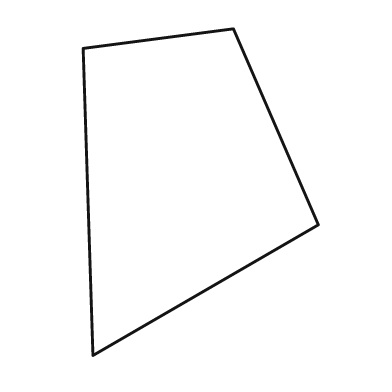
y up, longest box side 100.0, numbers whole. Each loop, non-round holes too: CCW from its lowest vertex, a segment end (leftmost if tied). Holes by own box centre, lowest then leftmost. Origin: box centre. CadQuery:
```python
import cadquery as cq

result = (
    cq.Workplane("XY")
    .moveTo(-33.0, -50.0)
    .lineTo(36.0, -10.0)
    .lineTo(10.0, 50.0)
    .lineTo(-36.0, 44.0)
    .close()
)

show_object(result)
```